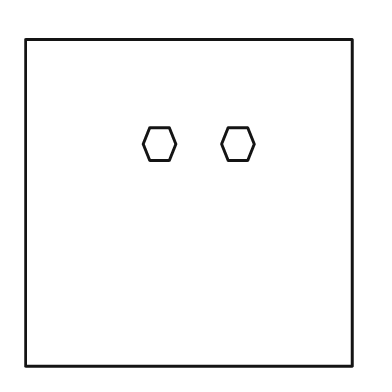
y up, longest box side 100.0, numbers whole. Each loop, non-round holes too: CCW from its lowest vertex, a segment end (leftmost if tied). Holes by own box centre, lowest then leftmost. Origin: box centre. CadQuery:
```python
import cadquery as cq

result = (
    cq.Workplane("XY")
    .moveTo(-50.0, -50.0)
    .lineTo(50.0, -50.0)
    .lineTo(50.0, 50.0)
    .lineTo(-50.0, 50.0)
    .close()
    .moveTo(-12.0, 13.0)
    .lineTo(-6.0, 13.0)
    .lineTo(-4.0, 18.0)
    .lineTo(-6.0, 23.0)
    .lineTo(-12.0, 23.0)
    .lineTo(-14.0, 18.0)
    .close()
    .moveTo(12.0, 13.0)
    .lineTo(18.0, 13.0)
    .lineTo(20.0, 18.0)
    .lineTo(18.0, 23.0)
    .lineTo(12.0, 23.0)
    .lineTo(10.0, 18.0)
    .close()
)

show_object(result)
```